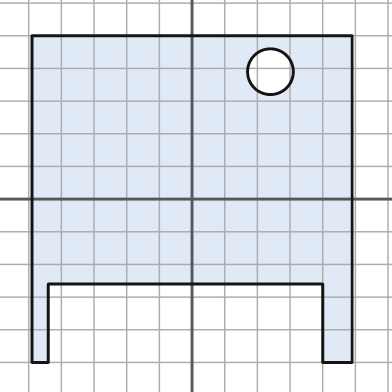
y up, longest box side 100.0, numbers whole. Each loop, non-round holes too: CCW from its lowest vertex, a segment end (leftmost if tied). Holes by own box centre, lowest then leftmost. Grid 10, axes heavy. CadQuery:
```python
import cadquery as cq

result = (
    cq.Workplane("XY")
    .moveTo(-49.0, -50.0)
    .lineTo(-44.0, -50.0)
    .lineTo(-44.0, -26.0)
    .lineTo(40.0, -26.0)
    .lineTo(40.0, -50.0)
    .lineTo(49.0, -50.0)
    .lineTo(49.0, 50.0)
    .lineTo(-49.0, 50.0)
    .close()
    .moveTo(24.0, 39.0)
    .circle(7.0)
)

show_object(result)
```